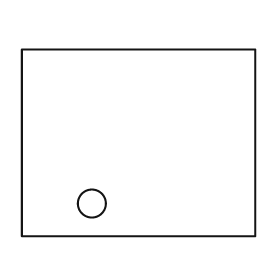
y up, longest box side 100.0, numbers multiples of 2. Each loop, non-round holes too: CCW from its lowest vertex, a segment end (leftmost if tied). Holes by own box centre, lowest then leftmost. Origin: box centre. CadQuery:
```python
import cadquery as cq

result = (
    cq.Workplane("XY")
    .moveTo(-50.0, -40.0)
    .lineTo(50.0, -40.0)
    .lineTo(50.0, 40.0)
    .lineTo(-50.0, 40.0)
    .close()
    .moveTo(-20.0, -26.0)
    .circle(6.0)
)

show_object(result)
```